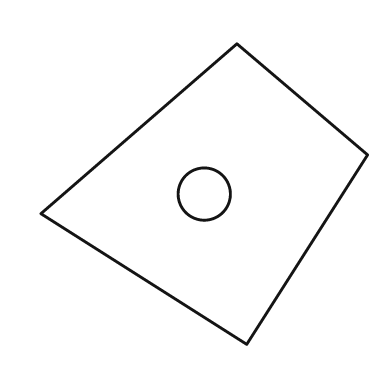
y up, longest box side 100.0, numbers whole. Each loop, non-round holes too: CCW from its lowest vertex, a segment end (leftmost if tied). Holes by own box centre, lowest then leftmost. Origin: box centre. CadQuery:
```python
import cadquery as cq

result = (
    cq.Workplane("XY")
    .moveTo(13.0, -46.0)
    .lineTo(50.0, 12.0)
    .lineTo(10.0, 46.0)
    .lineTo(-50.0, -6.0)
    .close()
    .moveTo(0.0, 0.0)
    .circle(8.0)
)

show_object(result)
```